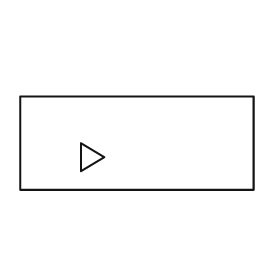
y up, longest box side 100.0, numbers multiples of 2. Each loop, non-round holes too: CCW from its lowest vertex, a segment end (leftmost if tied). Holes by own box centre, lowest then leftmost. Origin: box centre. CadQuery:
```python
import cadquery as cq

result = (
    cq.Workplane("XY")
    .moveTo(-50.0, -20.0)
    .lineTo(50.0, -20.0)
    .lineTo(50.0, 20.0)
    .lineTo(-50.0, 20.0)
    .close()
    .moveTo(-24.0, -12.0)
    .lineTo(-14.0, -6.0)
    .lineTo(-24.0, 0.0)
    .close()
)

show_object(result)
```